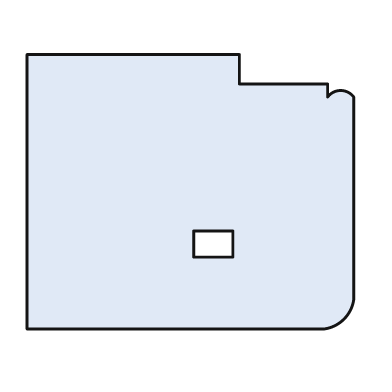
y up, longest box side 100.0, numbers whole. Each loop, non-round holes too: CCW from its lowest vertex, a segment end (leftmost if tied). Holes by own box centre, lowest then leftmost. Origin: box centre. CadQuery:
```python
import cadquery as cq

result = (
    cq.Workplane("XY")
    .moveTo(-50.0, -42.0)
    .lineTo(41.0, -42.0)
    .threePointArc((47.0, -39.0), (50.0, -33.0))
    .lineTo(50.0, 29.0)
    .threePointArc((46.0, 31.0), (42.0, 29.0))
    .lineTo(42.0, 33.0)
    .lineTo(15.0, 33.0)
    .lineTo(15.0, 42.0)
    .lineTo(-50.0, 42.0)
    .close()
    .moveTo(1.0, -20.0)
    .lineTo(13.0, -20.0)
    .lineTo(13.0, -12.0)
    .lineTo(1.0, -12.0)
    .close()
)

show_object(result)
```